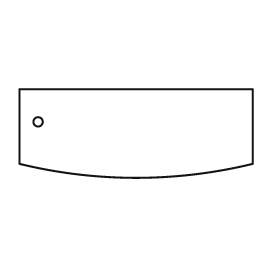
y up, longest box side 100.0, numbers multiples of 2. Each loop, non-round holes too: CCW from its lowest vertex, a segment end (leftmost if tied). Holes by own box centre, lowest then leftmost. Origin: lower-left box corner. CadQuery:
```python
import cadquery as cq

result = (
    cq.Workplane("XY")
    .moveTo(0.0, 6.0)
    .threePointArc((50.0, 0.0), (100.0, 6.0))
    .lineTo(100.0, 38.0)
    .lineTo(0.0, 38.0)
    .close()
    .moveTo(8.0, 24.0)
    .circle(2.0)
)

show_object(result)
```